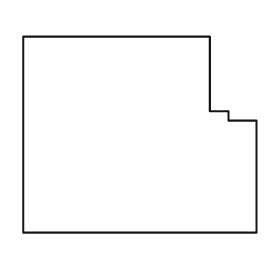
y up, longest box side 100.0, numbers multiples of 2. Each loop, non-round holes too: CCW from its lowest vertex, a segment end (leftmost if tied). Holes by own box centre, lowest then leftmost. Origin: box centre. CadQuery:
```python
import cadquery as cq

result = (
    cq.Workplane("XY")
    .moveTo(-50.0, -42.0)
    .lineTo(50.0, -42.0)
    .lineTo(50.0, 6.0)
    .lineTo(38.0, 6.0)
    .lineTo(38.0, 10.0)
    .lineTo(30.0, 10.0)
    .lineTo(30.0, 42.0)
    .lineTo(-50.0, 42.0)
    .close()
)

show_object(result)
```